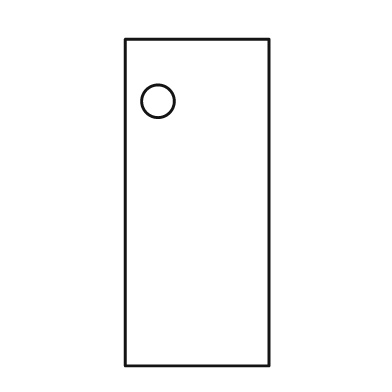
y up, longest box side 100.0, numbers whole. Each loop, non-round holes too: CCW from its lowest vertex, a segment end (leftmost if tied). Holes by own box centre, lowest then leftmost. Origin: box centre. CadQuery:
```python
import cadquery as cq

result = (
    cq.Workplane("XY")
    .moveTo(-22.0, -50.0)
    .lineTo(22.0, -50.0)
    .lineTo(22.0, 50.0)
    .lineTo(-22.0, 50.0)
    .close()
    .moveTo(-12.0, 31.0)
    .circle(5.0)
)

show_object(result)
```